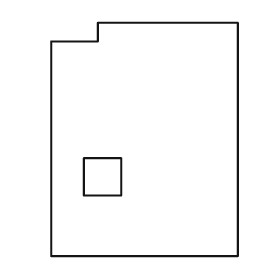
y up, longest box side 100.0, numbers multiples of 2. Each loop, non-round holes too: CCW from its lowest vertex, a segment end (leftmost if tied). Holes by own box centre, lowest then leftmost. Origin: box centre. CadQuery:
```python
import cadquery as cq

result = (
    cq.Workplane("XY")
    .moveTo(-40.0, -50.0)
    .lineTo(40.0, -50.0)
    .lineTo(40.0, 50.0)
    .lineTo(-20.0, 50.0)
    .lineTo(-20.0, 42.0)
    .lineTo(-40.0, 42.0)
    .close()
    .moveTo(-26.0, -24.0)
    .lineTo(-10.0, -24.0)
    .lineTo(-10.0, -8.0)
    .lineTo(-26.0, -8.0)
    .close()
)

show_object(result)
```